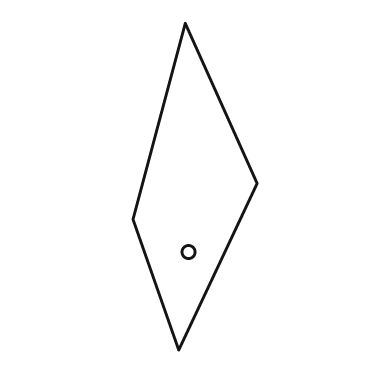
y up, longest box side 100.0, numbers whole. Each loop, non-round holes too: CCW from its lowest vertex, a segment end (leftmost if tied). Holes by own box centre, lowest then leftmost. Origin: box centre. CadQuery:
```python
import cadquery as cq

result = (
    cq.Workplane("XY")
    .moveTo(-5.0, -50.0)
    .lineTo(19.0, 1.0)
    .lineTo(-3.0, 50.0)
    .lineTo(-19.0, -10.0)
    .close()
    .moveTo(-2.0, -20.0)
    .circle(2.0)
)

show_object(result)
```